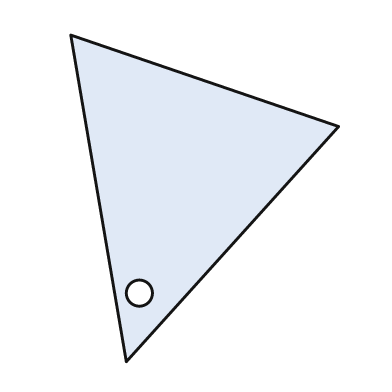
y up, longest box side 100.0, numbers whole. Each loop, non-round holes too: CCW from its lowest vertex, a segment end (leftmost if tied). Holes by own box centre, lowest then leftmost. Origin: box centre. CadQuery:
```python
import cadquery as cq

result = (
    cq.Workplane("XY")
    .moveTo(-24.0, -50.0)
    .lineTo(41.0, 22.0)
    .lineTo(-41.0, 50.0)
    .close()
    .moveTo(-20.0, -29.0)
    .circle(4.0)
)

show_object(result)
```